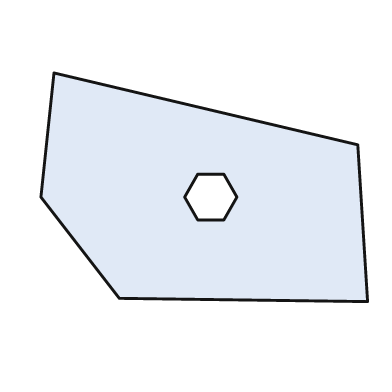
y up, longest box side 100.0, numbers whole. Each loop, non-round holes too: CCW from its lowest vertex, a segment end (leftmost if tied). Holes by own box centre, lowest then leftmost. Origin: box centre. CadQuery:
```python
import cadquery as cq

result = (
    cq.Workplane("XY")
    .moveTo(50.0, -35.0)
    .lineTo(47.0, 13.0)
    .lineTo(-46.0, 35.0)
    .lineTo(-50.0, -3.0)
    .lineTo(-26.0, -34.0)
    .close()
    .moveTo(-2.0, -10.0)
    .lineTo(6.0, -10.0)
    .lineTo(10.0, -3.0)
    .lineTo(6.0, 4.0)
    .lineTo(-2.0, 4.0)
    .lineTo(-6.0, -3.0)
    .close()
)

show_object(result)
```